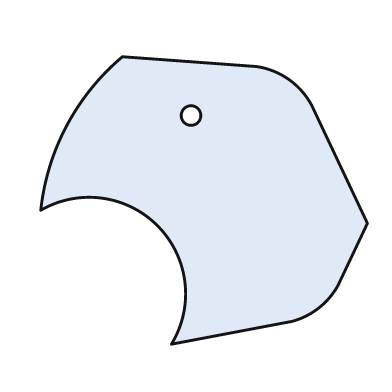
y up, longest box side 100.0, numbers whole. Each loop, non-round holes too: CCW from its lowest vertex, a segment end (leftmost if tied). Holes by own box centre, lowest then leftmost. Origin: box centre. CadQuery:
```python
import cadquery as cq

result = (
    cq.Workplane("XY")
    .moveTo(-10.0, -44.0)
    .lineTo(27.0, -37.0)
    .threePointArc((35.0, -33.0), (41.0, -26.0))
    .lineTo(50.0, -7.0)
    .lineTo(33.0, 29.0)
    .threePointArc((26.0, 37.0), (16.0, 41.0))
    .lineTo(-25.0, 44.0)
    .threePointArc((-42.0, 23.0), (-50.0, -3.0))
    .threePointArc((-14.0, -8.0), (-10.0, -44.0))
    .close()
    .moveTo(-4.0, 26.0)
    .circle(3.0)
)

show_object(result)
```